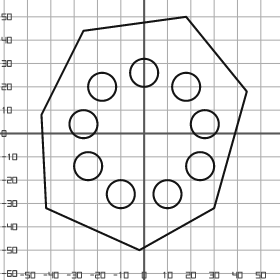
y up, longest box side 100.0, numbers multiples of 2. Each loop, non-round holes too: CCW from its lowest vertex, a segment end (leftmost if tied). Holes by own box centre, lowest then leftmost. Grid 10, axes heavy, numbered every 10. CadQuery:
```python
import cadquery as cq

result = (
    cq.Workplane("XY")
    .moveTo(-2.0, -50.0)
    .lineTo(30.0, -32.0)
    .lineTo(44.0, 18.0)
    .lineTo(18.0, 50.0)
    .lineTo(-26.0, 44.0)
    .lineTo(-44.0, 8.0)
    .lineTo(-42.0, -32.0)
    .close()
    .moveTo(-10.0, -26.0)
    .circle(6.0)
    .moveTo(10.0, -26.0)
    .circle(6.0)
    .moveTo(-24.0, -14.0)
    .circle(6.0)
    .moveTo(24.0, -14.0)
    .circle(6.0)
    .moveTo(-26.0, 4.0)
    .circle(6.0)
    .moveTo(26.0, 4.0)
    .circle(6.0)
    .moveTo(-18.0, 20.0)
    .circle(6.0)
    .moveTo(18.0, 20.0)
    .circle(6.0)
    .moveTo(0.0, 26.0)
    .circle(6.0)
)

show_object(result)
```